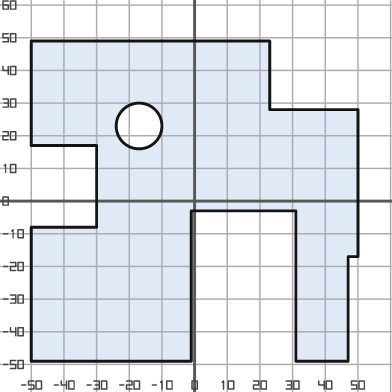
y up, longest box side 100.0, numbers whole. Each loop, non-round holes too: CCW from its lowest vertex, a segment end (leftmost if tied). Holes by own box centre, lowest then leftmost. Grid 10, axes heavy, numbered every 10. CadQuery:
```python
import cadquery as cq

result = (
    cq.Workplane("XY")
    .moveTo(-50.0, -49.0)
    .lineTo(-1.0, -49.0)
    .lineTo(-1.0, -3.0)
    .lineTo(31.0, -3.0)
    .lineTo(31.0, -49.0)
    .lineTo(47.0, -49.0)
    .lineTo(47.0, -17.0)
    .lineTo(50.0, -17.0)
    .lineTo(50.0, 28.0)
    .lineTo(23.0, 28.0)
    .lineTo(23.0, 49.0)
    .lineTo(-50.0, 49.0)
    .lineTo(-50.0, 17.0)
    .lineTo(-30.0, 17.0)
    .lineTo(-30.0, -8.0)
    .lineTo(-50.0, -8.0)
    .close()
    .moveTo(-17.0, 23.0)
    .circle(7.0)
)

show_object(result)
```